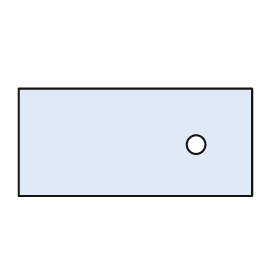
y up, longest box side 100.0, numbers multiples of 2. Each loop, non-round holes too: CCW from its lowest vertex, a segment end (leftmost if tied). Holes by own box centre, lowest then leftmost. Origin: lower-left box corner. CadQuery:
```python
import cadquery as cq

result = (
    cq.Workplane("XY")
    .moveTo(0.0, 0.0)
    .lineTo(100.0, 0.0)
    .lineTo(100.0, 46.0)
    .lineTo(0.0, 46.0)
    .close()
    .moveTo(76.0, 22.0)
    .circle(4.0)
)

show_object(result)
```